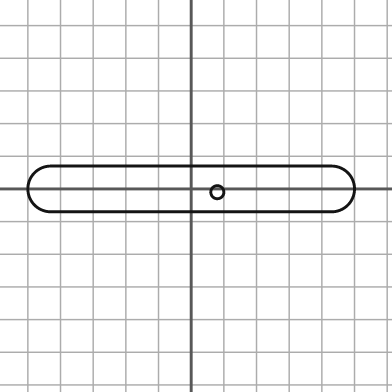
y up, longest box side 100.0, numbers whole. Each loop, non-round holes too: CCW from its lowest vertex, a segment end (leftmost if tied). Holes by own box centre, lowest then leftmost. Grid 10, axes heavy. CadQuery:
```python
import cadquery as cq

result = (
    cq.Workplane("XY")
    .moveTo(-43.0, -7.0)
    .lineTo(43.0, -7.0)
    .threePointArc((50.0, 0.0), (43.0, 7.0))
    .lineTo(-43.0, 7.0)
    .threePointArc((-50.0, 0.0), (-43.0, -7.0))
    .close()
    .moveTo(8.0, -1.0)
    .circle(2.0)
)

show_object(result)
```